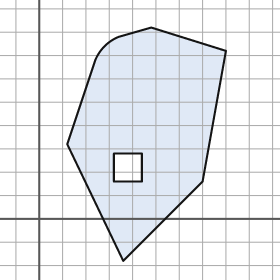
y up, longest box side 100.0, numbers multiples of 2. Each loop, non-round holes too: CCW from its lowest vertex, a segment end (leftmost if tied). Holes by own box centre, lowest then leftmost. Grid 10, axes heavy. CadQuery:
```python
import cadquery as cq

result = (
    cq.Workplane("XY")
    .moveTo(36.0, -18.0)
    .lineTo(70.0, 16.0)
    .lineTo(80.0, 72.0)
    .lineTo(48.0, 82.0)
    .lineTo(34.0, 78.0)
    .threePointArc((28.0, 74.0), (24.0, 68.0))
    .lineTo(12.0, 32.0)
    .close()
    .moveTo(32.0, 16.0)
    .lineTo(44.0, 16.0)
    .lineTo(44.0, 28.0)
    .lineTo(32.0, 28.0)
    .close()
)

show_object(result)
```